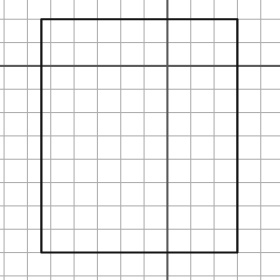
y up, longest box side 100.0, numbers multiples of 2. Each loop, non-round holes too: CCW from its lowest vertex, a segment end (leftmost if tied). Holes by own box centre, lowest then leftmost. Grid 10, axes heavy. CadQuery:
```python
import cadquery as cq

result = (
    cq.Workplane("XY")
    .moveTo(-54.0, -80.0)
    .lineTo(30.0, -80.0)
    .lineTo(30.0, 20.0)
    .lineTo(-54.0, 20.0)
    .close()
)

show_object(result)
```